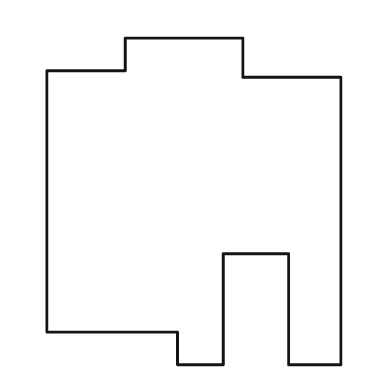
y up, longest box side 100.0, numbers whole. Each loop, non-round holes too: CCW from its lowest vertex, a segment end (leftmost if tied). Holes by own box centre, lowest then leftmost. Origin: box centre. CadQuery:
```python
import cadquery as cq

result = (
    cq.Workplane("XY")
    .moveTo(-5.0, -50.0)
    .lineTo(9.0, -50.0)
    .lineTo(9.0, -16.0)
    .lineTo(29.0, -16.0)
    .lineTo(29.0, -50.0)
    .lineTo(45.0, -50.0)
    .lineTo(45.0, 38.0)
    .lineTo(15.0, 38.0)
    .lineTo(15.0, 50.0)
    .lineTo(-21.0, 50.0)
    .lineTo(-21.0, 40.0)
    .lineTo(-45.0, 40.0)
    .lineTo(-45.0, -40.0)
    .lineTo(-5.0, -40.0)
    .close()
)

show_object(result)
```